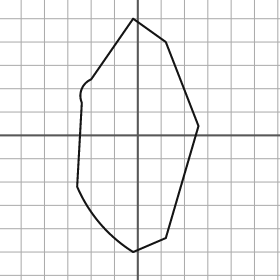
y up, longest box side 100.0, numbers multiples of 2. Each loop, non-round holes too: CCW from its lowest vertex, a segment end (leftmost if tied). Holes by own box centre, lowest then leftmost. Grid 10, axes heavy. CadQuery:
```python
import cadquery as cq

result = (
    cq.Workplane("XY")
    .moveTo(-2.0, -50.0)
    .lineTo(12.0, -44.0)
    .lineTo(26.0, 4.0)
    .lineTo(12.0, 40.0)
    .lineTo(-2.0, 50.0)
    .lineTo(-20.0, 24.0)
    .threePointArc((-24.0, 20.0), (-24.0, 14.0))
    .lineTo(-26.0, -22.0)
    .threePointArc((-16.0, -38.0), (-2.0, -50.0))
    .close()
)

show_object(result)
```